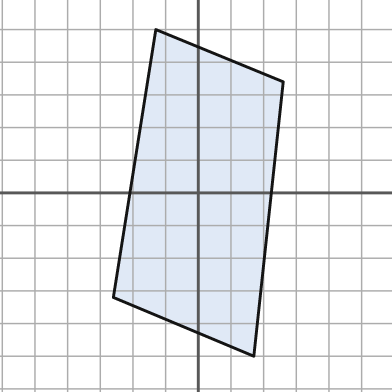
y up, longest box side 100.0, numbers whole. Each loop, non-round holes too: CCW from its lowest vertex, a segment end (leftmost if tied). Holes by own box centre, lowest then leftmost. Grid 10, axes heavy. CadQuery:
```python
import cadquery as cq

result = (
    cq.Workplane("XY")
    .moveTo(17.0, -50.0)
    .lineTo(26.0, 34.0)
    .lineTo(-13.0, 50.0)
    .lineTo(-26.0, -32.0)
    .close()
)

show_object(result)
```